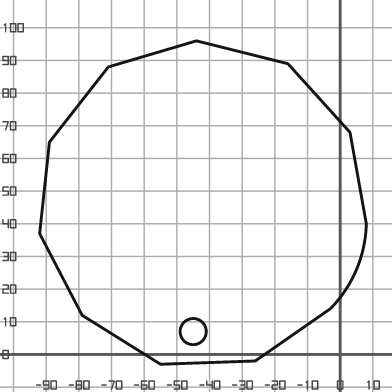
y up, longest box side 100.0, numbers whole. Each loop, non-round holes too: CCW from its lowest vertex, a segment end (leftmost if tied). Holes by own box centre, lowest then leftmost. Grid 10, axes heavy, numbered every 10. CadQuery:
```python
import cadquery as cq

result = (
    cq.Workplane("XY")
    .moveTo(-55.0, -3.0)
    .lineTo(-26.0, -2.0)
    .lineTo(-3.0, 14.0)
    .threePointArc((5.0, 26.0), (8.0, 40.0))
    .lineTo(3.0, 68.0)
    .lineTo(-16.0, 89.0)
    .lineTo(-44.0, 96.0)
    .lineTo(-71.0, 88.0)
    .lineTo(-89.0, 65.0)
    .lineTo(-92.0, 37.0)
    .lineTo(-79.0, 12.0)
    .close()
    .moveTo(-45.0, 7.0)
    .circle(4.0)
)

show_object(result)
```